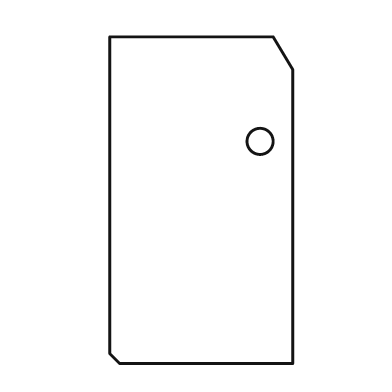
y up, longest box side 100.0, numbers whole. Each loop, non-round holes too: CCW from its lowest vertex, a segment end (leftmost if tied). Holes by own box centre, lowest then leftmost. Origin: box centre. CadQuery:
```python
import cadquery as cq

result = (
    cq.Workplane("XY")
    .moveTo(-25.0, -50.0)
    .lineTo(28.0, -50.0)
    .lineTo(28.0, 40.0)
    .lineTo(22.0, 50.0)
    .lineTo(-28.0, 50.0)
    .lineTo(-28.0, -47.0)
    .close()
    .moveTo(18.0, 18.0)
    .circle(4.0)
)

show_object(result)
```